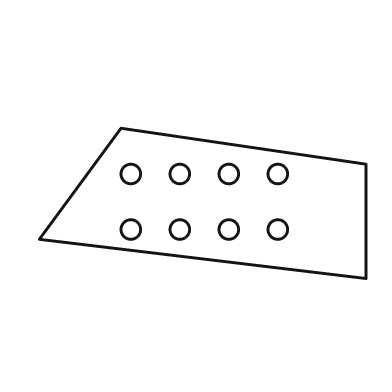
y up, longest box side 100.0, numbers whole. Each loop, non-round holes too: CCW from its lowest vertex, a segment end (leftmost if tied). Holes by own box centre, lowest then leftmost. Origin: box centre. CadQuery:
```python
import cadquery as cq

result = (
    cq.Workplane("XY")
    .moveTo(50.0, -23.0)
    .lineTo(50.0, 12.0)
    .lineTo(-25.0, 23.0)
    .lineTo(-50.0, -11.0)
    .close()
    .moveTo(-22.0, -8.0)
    .circle(3.0)
    .moveTo(-7.0, -8.0)
    .circle(3.0)
    .moveTo(8.0, -8.0)
    .circle(3.0)
    .moveTo(23.0, -8.0)
    .circle(3.0)
    .moveTo(-22.0, 9.0)
    .circle(3.0)
    .moveTo(-7.0, 9.0)
    .circle(3.0)
    .moveTo(8.0, 9.0)
    .circle(3.0)
    .moveTo(23.0, 9.0)
    .circle(3.0)
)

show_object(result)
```